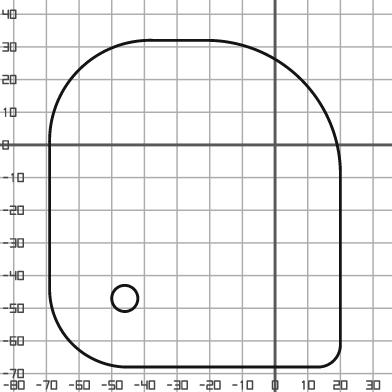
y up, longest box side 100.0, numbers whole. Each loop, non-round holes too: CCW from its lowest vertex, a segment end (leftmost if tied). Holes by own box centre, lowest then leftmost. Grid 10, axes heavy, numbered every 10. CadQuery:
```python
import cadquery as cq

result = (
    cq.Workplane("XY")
    .moveTo(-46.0, -68.0)
    .lineTo(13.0, -68.0)
    .threePointArc((18.0, -66.0), (20.0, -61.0))
    .lineTo(20.0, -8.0)
    .threePointArc((8.0, 20.0), (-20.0, 32.0))
    .lineTo(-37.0, 32.0)
    .threePointArc((-60.0, 23.0), (-69.0, 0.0))
    .lineTo(-69.0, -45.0)
    .threePointArc((-62.0, -61.0), (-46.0, -68.0))
    .close()
    .moveTo(-46.0, -47.0)
    .circle(4.0)
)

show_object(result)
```